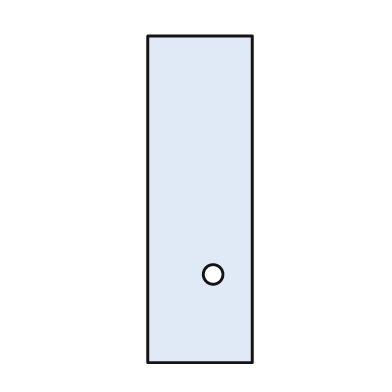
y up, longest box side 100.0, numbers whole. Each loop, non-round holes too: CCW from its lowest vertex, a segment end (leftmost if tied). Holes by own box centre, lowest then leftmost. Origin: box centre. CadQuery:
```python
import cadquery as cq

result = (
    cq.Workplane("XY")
    .moveTo(-16.0, -50.0)
    .lineTo(16.0, -50.0)
    .lineTo(16.0, 50.0)
    .lineTo(-16.0, 50.0)
    .close()
    .moveTo(4.0, -23.0)
    .circle(3.0)
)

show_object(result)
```